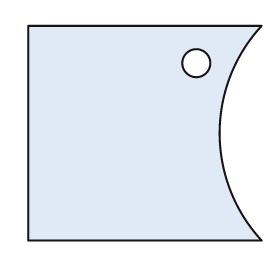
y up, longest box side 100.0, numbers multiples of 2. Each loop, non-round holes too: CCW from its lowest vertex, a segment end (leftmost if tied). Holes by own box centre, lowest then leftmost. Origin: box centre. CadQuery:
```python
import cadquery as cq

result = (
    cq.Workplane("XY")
    .moveTo(-50.0, -46.0)
    .lineTo(50.0, -46.0)
    .threePointArc((32.0, 0.0), (50.0, 46.0))
    .lineTo(-50.0, 46.0)
    .close()
    .moveTo(22.0, 30.0)
    .circle(6.0)
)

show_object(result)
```